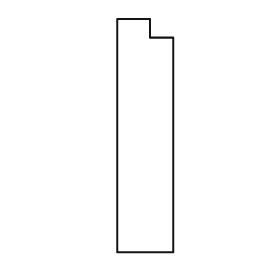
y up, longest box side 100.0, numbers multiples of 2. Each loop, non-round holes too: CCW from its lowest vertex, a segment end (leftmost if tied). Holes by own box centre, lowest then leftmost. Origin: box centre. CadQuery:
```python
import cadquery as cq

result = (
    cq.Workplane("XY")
    .moveTo(-12.0, -50.0)
    .lineTo(12.0, -50.0)
    .lineTo(12.0, 42.0)
    .lineTo(2.0, 42.0)
    .lineTo(2.0, 50.0)
    .lineTo(-12.0, 50.0)
    .close()
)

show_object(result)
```